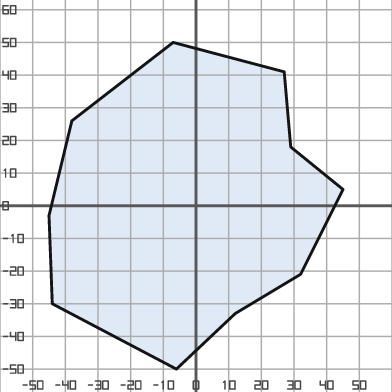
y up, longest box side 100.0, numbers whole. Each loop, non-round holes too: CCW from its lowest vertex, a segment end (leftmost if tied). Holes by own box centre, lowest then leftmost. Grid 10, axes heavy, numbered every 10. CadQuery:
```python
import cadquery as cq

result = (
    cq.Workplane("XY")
    .moveTo(-6.0, -50.0)
    .lineTo(12.0, -33.0)
    .lineTo(32.0, -21.0)
    .lineTo(45.0, 5.0)
    .lineTo(29.0, 18.0)
    .lineTo(27.0, 41.0)
    .lineTo(-7.0, 50.0)
    .lineTo(-38.0, 26.0)
    .lineTo(-45.0, -3.0)
    .lineTo(-44.0, -30.0)
    .close()
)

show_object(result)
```